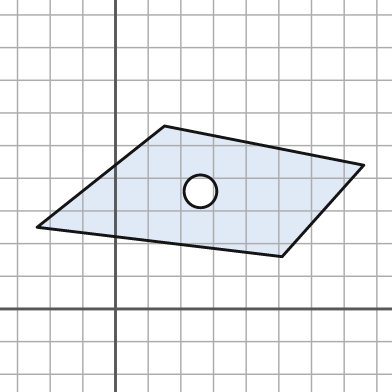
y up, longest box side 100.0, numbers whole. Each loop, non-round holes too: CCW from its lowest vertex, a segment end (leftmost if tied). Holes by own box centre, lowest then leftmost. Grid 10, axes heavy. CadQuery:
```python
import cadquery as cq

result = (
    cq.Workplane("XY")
    .moveTo(51.0, 16.0)
    .lineTo(76.0, 44.0)
    .lineTo(15.0, 56.0)
    .lineTo(-24.0, 25.0)
    .close()
    .moveTo(26.0, 36.0)
    .circle(5.0)
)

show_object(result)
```